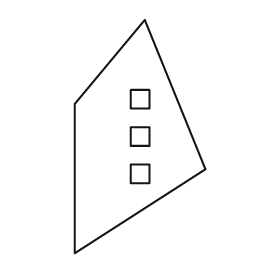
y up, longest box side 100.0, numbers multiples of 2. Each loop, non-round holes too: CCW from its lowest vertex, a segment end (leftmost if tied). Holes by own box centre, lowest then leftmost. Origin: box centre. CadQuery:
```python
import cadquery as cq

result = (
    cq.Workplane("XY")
    .moveTo(-28.0, -50.0)
    .lineTo(28.0, -14.0)
    .lineTo(2.0, 50.0)
    .lineTo(-28.0, 14.0)
    .close()
    .moveTo(-4.0, -20.0)
    .lineTo(4.0, -20.0)
    .lineTo(4.0, -12.0)
    .lineTo(-4.0, -12.0)
    .close()
    .moveTo(-4.0, -4.0)
    .lineTo(4.0, -4.0)
    .lineTo(4.0, 4.0)
    .lineTo(-4.0, 4.0)
    .close()
    .moveTo(-4.0, 12.0)
    .lineTo(4.0, 12.0)
    .lineTo(4.0, 20.0)
    .lineTo(-4.0, 20.0)
    .close()
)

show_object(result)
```